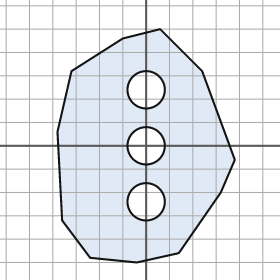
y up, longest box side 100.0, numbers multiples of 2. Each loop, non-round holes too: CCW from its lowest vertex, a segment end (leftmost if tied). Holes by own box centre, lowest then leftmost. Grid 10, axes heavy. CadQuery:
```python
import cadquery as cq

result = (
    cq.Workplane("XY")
    .moveTo(-4.0, -50.0)
    .lineTo(14.0, -46.0)
    .lineTo(32.0, -20.0)
    .lineTo(38.0, -6.0)
    .lineTo(24.0, 32.0)
    .lineTo(6.0, 50.0)
    .lineTo(-10.0, 46.0)
    .lineTo(-32.0, 32.0)
    .lineTo(-38.0, 6.0)
    .lineTo(-36.0, -32.0)
    .lineTo(-24.0, -48.0)
    .close()
    .moveTo(0.0, -24.0)
    .circle(8.0)
    .moveTo(0.0, 0.0)
    .circle(8.0)
    .moveTo(0.0, 24.0)
    .circle(8.0)
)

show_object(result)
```